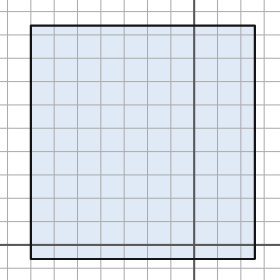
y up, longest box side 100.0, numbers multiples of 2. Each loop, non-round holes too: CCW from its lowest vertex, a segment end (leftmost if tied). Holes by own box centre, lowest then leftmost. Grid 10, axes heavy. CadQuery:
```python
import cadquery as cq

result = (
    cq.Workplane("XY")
    .moveTo(-70.0, -6.0)
    .lineTo(26.0, -6.0)
    .lineTo(26.0, 94.0)
    .lineTo(-70.0, 94.0)
    .close()
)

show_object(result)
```